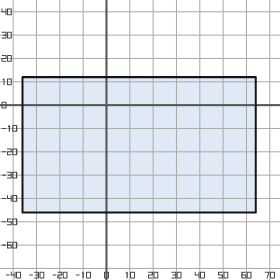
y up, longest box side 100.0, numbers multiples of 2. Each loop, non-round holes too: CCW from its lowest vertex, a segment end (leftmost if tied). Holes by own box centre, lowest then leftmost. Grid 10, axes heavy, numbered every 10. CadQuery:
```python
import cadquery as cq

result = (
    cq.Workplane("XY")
    .moveTo(-36.0, -46.0)
    .lineTo(64.0, -46.0)
    .lineTo(64.0, 12.0)
    .lineTo(-36.0, 12.0)
    .close()
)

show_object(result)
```